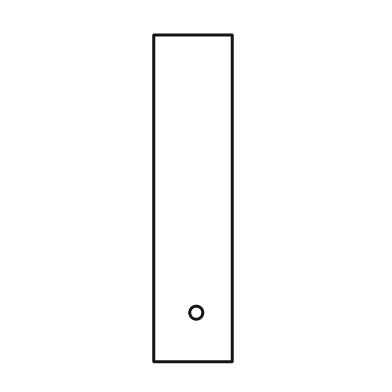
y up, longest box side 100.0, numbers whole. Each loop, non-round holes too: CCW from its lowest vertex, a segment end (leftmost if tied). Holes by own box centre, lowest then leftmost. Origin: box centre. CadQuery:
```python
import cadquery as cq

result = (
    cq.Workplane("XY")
    .moveTo(-12.0, -50.0)
    .lineTo(12.0, -50.0)
    .lineTo(12.0, 50.0)
    .lineTo(-12.0, 50.0)
    .close()
    .moveTo(1.0, -35.0)
    .circle(2.0)
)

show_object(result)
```